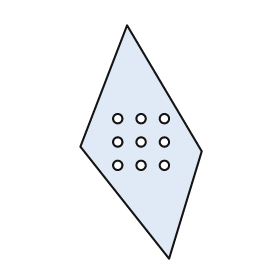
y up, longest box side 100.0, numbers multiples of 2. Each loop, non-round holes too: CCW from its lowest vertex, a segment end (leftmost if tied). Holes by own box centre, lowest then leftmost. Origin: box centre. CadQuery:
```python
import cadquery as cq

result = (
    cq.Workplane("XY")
    .moveTo(12.0, -50.0)
    .lineTo(26.0, -4.0)
    .lineTo(-6.0, 50.0)
    .lineTo(-26.0, -2.0)
    .close()
    .moveTo(-10.0, -10.0)
    .circle(2.0)
    .moveTo(0.0, -10.0)
    .circle(2.0)
    .moveTo(10.0, -10.0)
    .circle(2.0)
    .moveTo(-10.0, 0.0)
    .circle(2.0)
    .moveTo(0.0, 0.0)
    .circle(2.0)
    .moveTo(10.0, 0.0)
    .circle(2.0)
    .moveTo(-10.0, 10.0)
    .circle(2.0)
    .moveTo(0.0, 10.0)
    .circle(2.0)
    .moveTo(10.0, 10.0)
    .circle(2.0)
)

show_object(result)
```